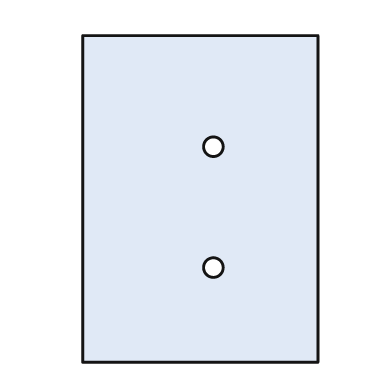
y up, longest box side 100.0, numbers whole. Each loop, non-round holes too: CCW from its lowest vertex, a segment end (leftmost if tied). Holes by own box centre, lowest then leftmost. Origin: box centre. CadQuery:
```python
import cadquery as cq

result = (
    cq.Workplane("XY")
    .moveTo(-36.0, -50.0)
    .lineTo(36.0, -50.0)
    .lineTo(36.0, 50.0)
    .lineTo(-36.0, 50.0)
    .close()
    .moveTo(4.0, -21.0)
    .circle(3.0)
    .moveTo(4.0, 16.0)
    .circle(3.0)
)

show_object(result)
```